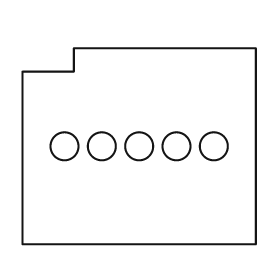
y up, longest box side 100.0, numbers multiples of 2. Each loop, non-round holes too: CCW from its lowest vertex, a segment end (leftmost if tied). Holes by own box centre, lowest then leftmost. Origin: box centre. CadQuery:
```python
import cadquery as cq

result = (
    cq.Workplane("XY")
    .moveTo(-50.0, -42.0)
    .lineTo(50.0, -42.0)
    .lineTo(50.0, 42.0)
    .lineTo(-28.0, 42.0)
    .lineTo(-28.0, 32.0)
    .lineTo(-50.0, 32.0)
    .close()
    .moveTo(-32.0, 0.0)
    .circle(6.0)
    .moveTo(-16.0, 0.0)
    .circle(6.0)
    .moveTo(0.0, 0.0)
    .circle(6.0)
    .moveTo(16.0, 0.0)
    .circle(6.0)
    .moveTo(32.0, 0.0)
    .circle(6.0)
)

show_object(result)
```